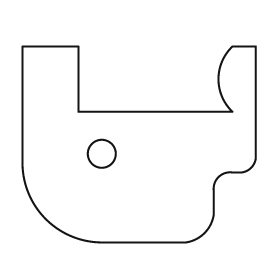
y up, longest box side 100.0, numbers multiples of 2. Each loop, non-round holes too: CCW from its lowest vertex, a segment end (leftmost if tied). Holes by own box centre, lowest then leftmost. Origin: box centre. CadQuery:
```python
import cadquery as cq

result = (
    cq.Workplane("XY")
    .moveTo(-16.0, -42.0)
    .lineTo(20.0, -42.0)
    .threePointArc((28.0, -38.0), (32.0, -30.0))
    .lineTo(32.0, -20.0)
    .threePointArc((34.0, -14.0), (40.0, -12.0))
    .lineTo(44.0, -12.0)
    .threePointArc((48.0, -10.0), (50.0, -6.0))
    .lineTo(50.0, 42.0)
    .lineTo(40.0, 42.0)
    .threePointArc((34.0, 28.0), (40.0, 14.0))
    .lineTo(-26.0, 14.0)
    .lineTo(-26.0, 42.0)
    .lineTo(-50.0, 42.0)
    .lineTo(-50.0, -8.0)
    .threePointArc((-40.0, -32.0), (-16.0, -42.0))
    .close()
    .moveTo(-16.0, -4.0)
    .circle(6.0)
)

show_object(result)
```